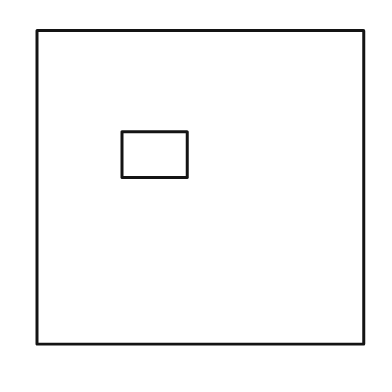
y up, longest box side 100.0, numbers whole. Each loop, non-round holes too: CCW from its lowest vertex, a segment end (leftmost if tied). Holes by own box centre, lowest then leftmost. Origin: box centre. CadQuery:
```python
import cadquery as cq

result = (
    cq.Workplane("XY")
    .moveTo(-50.0, -48.0)
    .lineTo(50.0, -48.0)
    .lineTo(50.0, 48.0)
    .lineTo(-50.0, 48.0)
    .close()
    .moveTo(-24.0, 3.0)
    .lineTo(-4.0, 3.0)
    .lineTo(-4.0, 17.0)
    .lineTo(-24.0, 17.0)
    .close()
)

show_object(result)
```